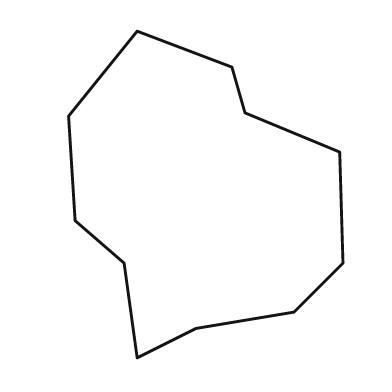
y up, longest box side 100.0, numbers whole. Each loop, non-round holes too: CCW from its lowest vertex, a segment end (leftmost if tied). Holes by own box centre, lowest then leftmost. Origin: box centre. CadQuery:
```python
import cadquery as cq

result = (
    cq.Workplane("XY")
    .moveTo(-21.0, -50.0)
    .lineTo(-3.0, -41.0)
    .lineTo(27.0, -36.0)
    .lineTo(42.0, -21.0)
    .lineTo(41.0, 13.0)
    .lineTo(12.0, 25.0)
    .lineTo(8.0, 39.0)
    .lineTo(-21.0, 50.0)
    .lineTo(-42.0, 24.0)
    .lineTo(-40.0, -8.0)
    .lineTo(-25.0, -21.0)
    .close()
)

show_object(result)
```